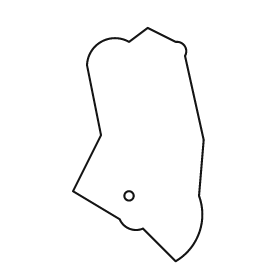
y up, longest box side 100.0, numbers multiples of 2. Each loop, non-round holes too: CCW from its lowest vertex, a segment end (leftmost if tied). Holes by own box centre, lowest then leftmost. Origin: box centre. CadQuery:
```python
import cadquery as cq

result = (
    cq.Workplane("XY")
    .moveTo(16.0, -50.0)
    .threePointArc((26.0, -38.0), (26.0, -22.0))
    .lineTo(28.0, 2.0)
    .lineTo(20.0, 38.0)
    .threePointArc((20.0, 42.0), (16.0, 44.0))
    .lineTo(4.0, 50.0)
    .lineTo(-4.0, 44.0)
    .threePointArc((-16.0, 44.0), (-22.0, 34.0))
    .lineTo(-16.0, 4.0)
    .lineTo(-28.0, -20.0)
    .lineTo(-8.0, -32.0)
    .threePointArc((-4.0, -36.0), (2.0, -36.0))
    .close()
    .moveTo(-4.0, -22.0)
    .circle(2.0)
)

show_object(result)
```